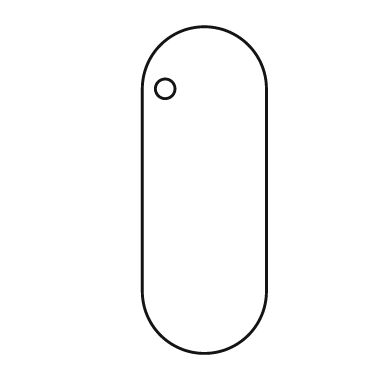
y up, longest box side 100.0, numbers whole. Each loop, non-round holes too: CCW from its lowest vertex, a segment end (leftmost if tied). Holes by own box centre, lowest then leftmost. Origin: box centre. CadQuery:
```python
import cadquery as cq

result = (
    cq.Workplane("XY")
    .moveTo(-19.0, -31.0)
    .threePointArc((0.0, -50.0), (19.0, -31.0))
    .lineTo(19.0, 31.0)
    .threePointArc((0.0, 50.0), (-19.0, 31.0))
    .close()
    .moveTo(-12.0, 31.0)
    .circle(3.0)
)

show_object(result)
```